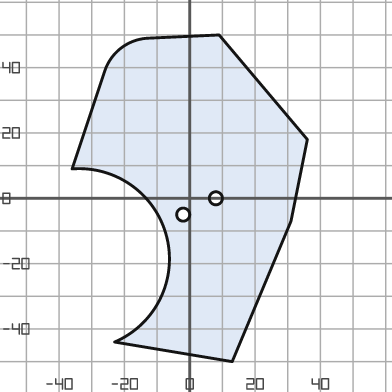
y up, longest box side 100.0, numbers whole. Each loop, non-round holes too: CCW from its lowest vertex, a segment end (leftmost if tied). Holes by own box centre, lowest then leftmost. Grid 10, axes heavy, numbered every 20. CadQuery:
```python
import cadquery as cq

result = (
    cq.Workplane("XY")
    .moveTo(13.0, -50.0)
    .lineTo(31.0, -7.0)
    .lineTo(36.0, 18.0)
    .lineTo(9.0, 50.0)
    .lineTo(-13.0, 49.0)
    .threePointArc((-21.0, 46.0), (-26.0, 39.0))
    .lineTo(-36.0, 9.0)
    .threePointArc((-7.0, -12.0), (-23.0, -44.0))
    .close()
    .moveTo(-2.0, -5.0)
    .circle(2.0)
    .moveTo(8.0, 0.0)
    .circle(2.0)
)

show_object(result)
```